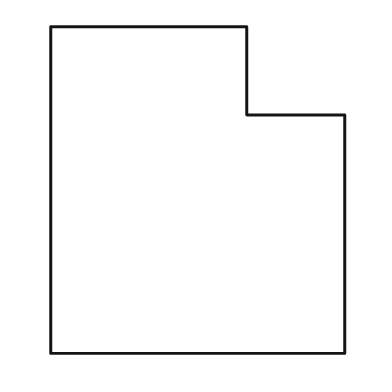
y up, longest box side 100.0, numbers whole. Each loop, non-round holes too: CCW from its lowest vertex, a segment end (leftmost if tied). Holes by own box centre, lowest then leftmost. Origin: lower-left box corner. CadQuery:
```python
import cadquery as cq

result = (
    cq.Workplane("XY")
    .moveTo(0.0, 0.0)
    .lineTo(90.0, 0.0)
    .lineTo(90.0, 73.0)
    .lineTo(60.0, 73.0)
    .lineTo(60.0, 100.0)
    .lineTo(0.0, 100.0)
    .close()
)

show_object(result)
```